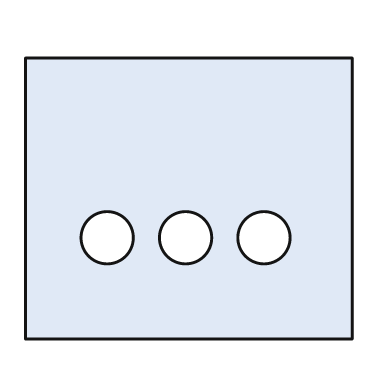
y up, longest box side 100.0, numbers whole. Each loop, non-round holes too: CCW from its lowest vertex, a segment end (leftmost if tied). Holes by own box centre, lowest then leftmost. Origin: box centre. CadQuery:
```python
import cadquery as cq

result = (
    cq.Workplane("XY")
    .moveTo(-50.0, -43.0)
    .lineTo(50.0, -43.0)
    .lineTo(50.0, 43.0)
    .lineTo(-50.0, 43.0)
    .close()
    .moveTo(-25.0, -12.0)
    .circle(8.0)
    .moveTo(-1.0, -12.0)
    .circle(8.0)
    .moveTo(23.0, -12.0)
    .circle(8.0)
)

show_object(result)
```